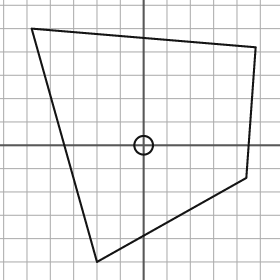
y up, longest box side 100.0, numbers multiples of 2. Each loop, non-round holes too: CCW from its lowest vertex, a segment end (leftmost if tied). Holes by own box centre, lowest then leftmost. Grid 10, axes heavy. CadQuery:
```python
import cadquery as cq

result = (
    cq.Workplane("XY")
    .moveTo(-20.0, -50.0)
    .lineTo(44.0, -14.0)
    .lineTo(48.0, 42.0)
    .lineTo(-48.0, 50.0)
    .close()
    .moveTo(0.0, 0.0)
    .circle(4.0)
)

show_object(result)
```